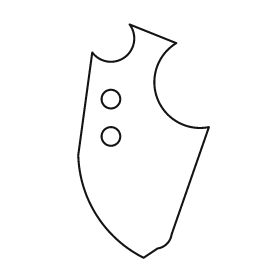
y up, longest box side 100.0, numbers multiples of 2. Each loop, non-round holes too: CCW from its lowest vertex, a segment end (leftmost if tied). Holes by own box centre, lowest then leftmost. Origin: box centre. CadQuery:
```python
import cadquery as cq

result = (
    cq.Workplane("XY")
    .moveTo(0.0, -50.0)
    .lineTo(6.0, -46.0)
    .threePointArc((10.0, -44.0), (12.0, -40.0))
    .lineTo(28.0, 6.0)
    .threePointArc((6.0, 18.0), (14.0, 42.0))
    .lineTo(-6.0, 50.0)
    .threePointArc((-8.0, 36.0), (-22.0, 38.0))
    .lineTo(-28.0, -6.0)
    .threePointArc((-20.0, -32.0), (0.0, -50.0))
    .close()
    .moveTo(-14.0, 2.0)
    .circle(4.0)
    .moveTo(-14.0, 18.0)
    .circle(4.0)
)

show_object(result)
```